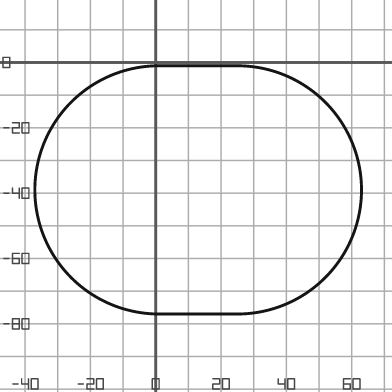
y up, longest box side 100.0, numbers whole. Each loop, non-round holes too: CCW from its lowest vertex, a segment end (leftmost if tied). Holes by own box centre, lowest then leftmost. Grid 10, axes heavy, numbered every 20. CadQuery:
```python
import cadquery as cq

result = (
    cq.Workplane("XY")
    .moveTo(1.0, -77.0)
    .lineTo(25.0, -77.0)
    .threePointArc((63.0, -39.0), (25.0, -1.0))
    .lineTo(1.0, -1.0)
    .threePointArc((-37.0, -39.0), (1.0, -77.0))
    .close()
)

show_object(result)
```